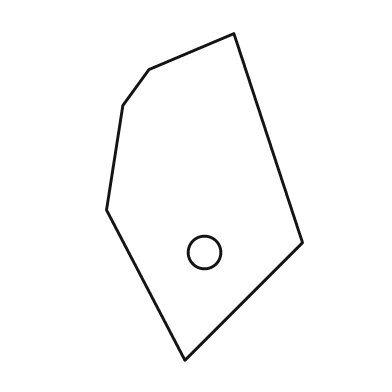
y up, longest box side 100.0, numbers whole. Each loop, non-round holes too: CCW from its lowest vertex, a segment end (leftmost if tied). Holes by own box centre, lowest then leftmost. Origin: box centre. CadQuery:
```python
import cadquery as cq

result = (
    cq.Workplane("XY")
    .moveTo(-6.0, -50.0)
    .lineTo(30.0, -14.0)
    .lineTo(9.0, 50.0)
    .lineTo(-17.0, 39.0)
    .lineTo(-25.0, 28.0)
    .lineTo(-30.0, -4.0)
    .close()
    .moveTo(0.0, -17.0)
    .circle(5.0)
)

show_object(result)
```